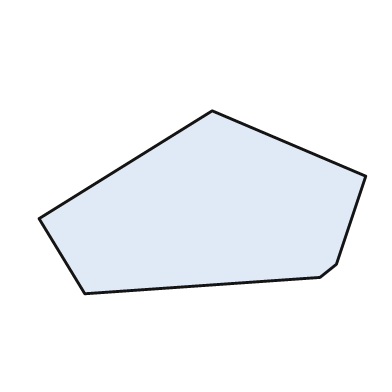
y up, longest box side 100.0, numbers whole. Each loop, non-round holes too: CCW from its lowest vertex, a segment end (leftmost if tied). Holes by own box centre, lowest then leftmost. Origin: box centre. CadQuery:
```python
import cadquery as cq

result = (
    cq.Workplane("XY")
    .moveTo(-36.0, -28.0)
    .lineTo(36.0, -23.0)
    .lineTo(41.0, -19.0)
    .lineTo(50.0, 8.0)
    .lineTo(3.0, 28.0)
    .lineTo(-50.0, -5.0)
    .close()
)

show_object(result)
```